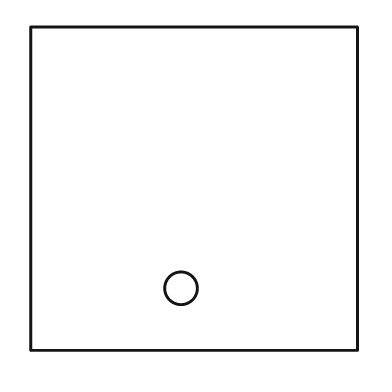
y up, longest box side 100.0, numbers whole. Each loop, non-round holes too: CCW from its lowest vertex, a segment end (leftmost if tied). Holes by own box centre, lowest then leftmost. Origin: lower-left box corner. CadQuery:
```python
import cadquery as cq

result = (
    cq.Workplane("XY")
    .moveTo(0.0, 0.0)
    .lineTo(100.0, 0.0)
    .lineTo(100.0, 99.0)
    .lineTo(0.0, 99.0)
    .close()
    .moveTo(46.0, 19.0)
    .circle(5.0)
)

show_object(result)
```